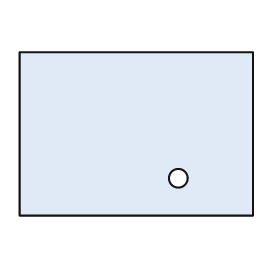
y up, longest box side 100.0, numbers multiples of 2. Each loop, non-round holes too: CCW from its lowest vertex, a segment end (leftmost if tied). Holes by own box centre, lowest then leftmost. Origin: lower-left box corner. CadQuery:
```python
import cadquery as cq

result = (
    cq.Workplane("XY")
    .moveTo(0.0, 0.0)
    .lineTo(100.0, 0.0)
    .lineTo(100.0, 70.0)
    .lineTo(0.0, 70.0)
    .close()
    .moveTo(68.0, 16.0)
    .circle(4.0)
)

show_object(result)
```